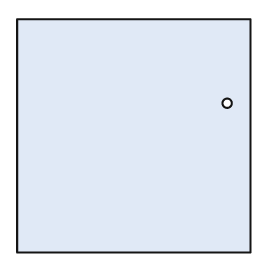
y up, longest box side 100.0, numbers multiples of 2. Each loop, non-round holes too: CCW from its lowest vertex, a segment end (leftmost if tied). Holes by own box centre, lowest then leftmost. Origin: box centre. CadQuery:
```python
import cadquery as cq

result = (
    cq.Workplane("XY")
    .moveTo(-50.0, -50.0)
    .lineTo(50.0, -50.0)
    .lineTo(50.0, 50.0)
    .lineTo(-50.0, 50.0)
    .close()
    .moveTo(40.0, 14.0)
    .circle(2.0)
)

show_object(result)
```